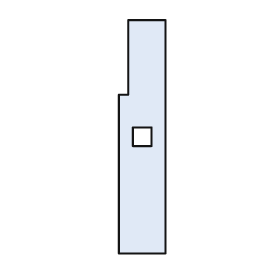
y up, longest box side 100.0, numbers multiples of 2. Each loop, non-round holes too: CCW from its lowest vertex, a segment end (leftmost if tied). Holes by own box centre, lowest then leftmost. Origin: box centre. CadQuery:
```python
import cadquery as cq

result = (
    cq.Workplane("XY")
    .moveTo(-10.0, -50.0)
    .lineTo(10.0, -50.0)
    .lineTo(10.0, 50.0)
    .lineTo(-6.0, 50.0)
    .lineTo(-6.0, 18.0)
    .lineTo(-10.0, 18.0)
    .close()
    .moveTo(-4.0, -4.0)
    .lineTo(4.0, -4.0)
    .lineTo(4.0, 4.0)
    .lineTo(-4.0, 4.0)
    .close()
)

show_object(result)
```